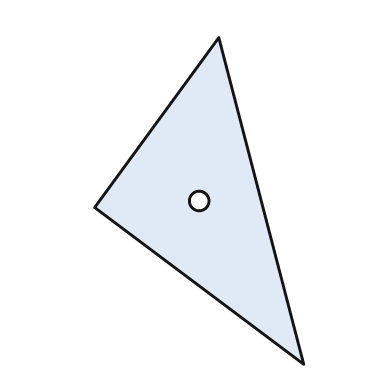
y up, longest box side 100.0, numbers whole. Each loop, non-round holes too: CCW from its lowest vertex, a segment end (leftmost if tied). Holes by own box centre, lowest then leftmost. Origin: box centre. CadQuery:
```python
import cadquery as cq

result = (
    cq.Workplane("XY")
    .moveTo(32.0, -50.0)
    .lineTo(6.0, 50.0)
    .lineTo(-32.0, -2.0)
    .close()
    .moveTo(0.0, 0.0)
    .circle(3.0)
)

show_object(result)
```